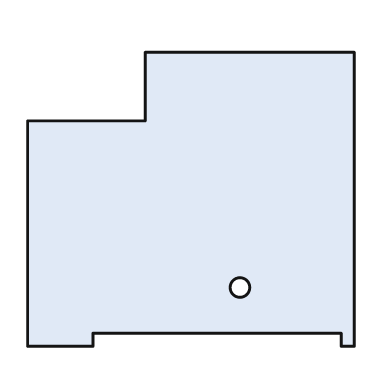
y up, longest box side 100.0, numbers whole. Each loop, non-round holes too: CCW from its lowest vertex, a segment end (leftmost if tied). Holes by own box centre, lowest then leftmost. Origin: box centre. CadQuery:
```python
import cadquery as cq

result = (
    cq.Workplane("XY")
    .moveTo(-50.0, -45.0)
    .lineTo(-30.0, -45.0)
    .lineTo(-30.0, -41.0)
    .lineTo(46.0, -41.0)
    .lineTo(46.0, -45.0)
    .lineTo(50.0, -45.0)
    .lineTo(50.0, 45.0)
    .lineTo(-14.0, 45.0)
    .lineTo(-14.0, 24.0)
    .lineTo(-50.0, 24.0)
    .close()
    .moveTo(15.0, -27.0)
    .circle(3.0)
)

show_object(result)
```